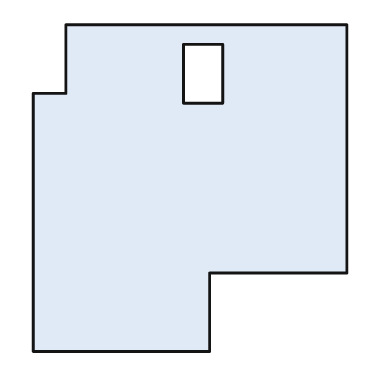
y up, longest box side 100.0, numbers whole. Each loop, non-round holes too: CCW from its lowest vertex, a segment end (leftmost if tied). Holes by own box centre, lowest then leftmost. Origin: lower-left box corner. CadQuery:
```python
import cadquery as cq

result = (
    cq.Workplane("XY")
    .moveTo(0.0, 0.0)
    .lineTo(54.0, 0.0)
    .lineTo(54.0, 24.0)
    .lineTo(96.0, 24.0)
    .lineTo(96.0, 100.0)
    .lineTo(10.0, 100.0)
    .lineTo(10.0, 79.0)
    .lineTo(0.0, 79.0)
    .close()
    .moveTo(46.0, 76.0)
    .lineTo(58.0, 76.0)
    .lineTo(58.0, 94.0)
    .lineTo(46.0, 94.0)
    .close()
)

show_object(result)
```